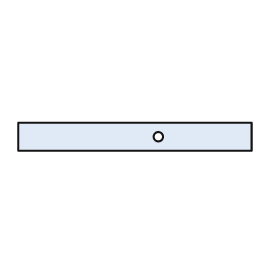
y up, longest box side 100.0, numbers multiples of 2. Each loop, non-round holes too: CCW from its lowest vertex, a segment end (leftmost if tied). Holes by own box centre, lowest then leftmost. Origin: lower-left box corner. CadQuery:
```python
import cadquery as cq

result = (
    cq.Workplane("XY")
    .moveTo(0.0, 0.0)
    .lineTo(100.0, 0.0)
    .lineTo(100.0, 12.0)
    .lineTo(0.0, 12.0)
    .close()
    .moveTo(60.0, 6.0)
    .circle(2.0)
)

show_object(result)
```